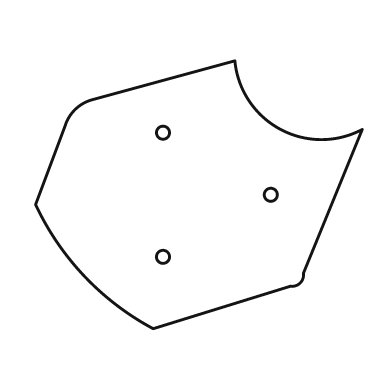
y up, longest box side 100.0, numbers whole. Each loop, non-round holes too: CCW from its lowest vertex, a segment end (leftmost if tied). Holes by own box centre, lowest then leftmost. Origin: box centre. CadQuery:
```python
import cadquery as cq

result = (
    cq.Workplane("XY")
    .moveTo(-14.0, -41.0)
    .lineTo(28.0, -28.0)
    .threePointArc((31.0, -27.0), (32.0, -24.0))
    .lineTo(50.0, 20.0)
    .threePointArc((25.0, 20.0), (11.0, 41.0))
    .lineTo(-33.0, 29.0)
    .threePointArc((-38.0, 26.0), (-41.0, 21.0))
    .lineTo(-50.0, -3.0)
    .threePointArc((-35.0, -25.0), (-14.0, -41.0))
    .close()
    .moveTo(-11.0, -19.0)
    .circle(2.0)
    .moveTo(22.0, 0.0)
    .circle(2.0)
    .moveTo(-11.0, 19.0)
    .circle(2.0)
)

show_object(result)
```